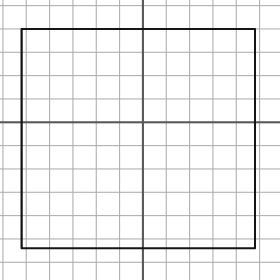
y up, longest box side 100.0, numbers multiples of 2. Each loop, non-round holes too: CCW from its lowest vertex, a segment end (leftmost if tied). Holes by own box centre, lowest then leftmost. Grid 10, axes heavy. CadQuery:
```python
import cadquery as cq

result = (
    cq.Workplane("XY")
    .moveTo(-52.0, -54.0)
    .lineTo(48.0, -54.0)
    .lineTo(48.0, 40.0)
    .lineTo(-52.0, 40.0)
    .close()
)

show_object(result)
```